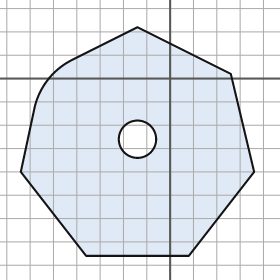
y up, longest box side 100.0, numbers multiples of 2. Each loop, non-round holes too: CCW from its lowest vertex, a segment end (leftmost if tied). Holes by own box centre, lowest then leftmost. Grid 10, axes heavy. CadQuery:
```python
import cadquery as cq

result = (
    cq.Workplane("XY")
    .moveTo(-36.0, -76.0)
    .lineTo(8.0, -76.0)
    .lineTo(36.0, -40.0)
    .lineTo(26.0, 2.0)
    .lineTo(-14.0, 22.0)
    .lineTo(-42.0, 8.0)
    .threePointArc((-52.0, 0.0), (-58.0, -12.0))
    .lineTo(-64.0, -40.0)
    .close()
    .moveTo(-14.0, -26.0)
    .circle(8.0)
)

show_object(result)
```